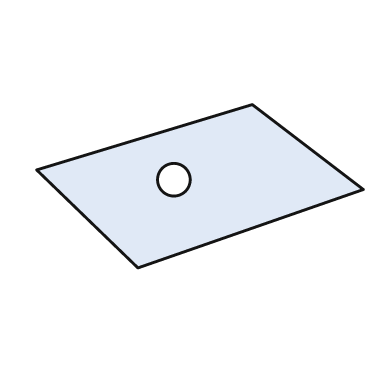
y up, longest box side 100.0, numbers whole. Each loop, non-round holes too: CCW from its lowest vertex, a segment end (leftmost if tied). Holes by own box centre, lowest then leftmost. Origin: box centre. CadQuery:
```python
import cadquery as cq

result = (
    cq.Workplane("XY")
    .moveTo(-19.0, -25.0)
    .lineTo(50.0, -1.0)
    .lineTo(16.0, 25.0)
    .lineTo(-50.0, 5.0)
    .close()
    .moveTo(-8.0, 2.0)
    .circle(5.0)
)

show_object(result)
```